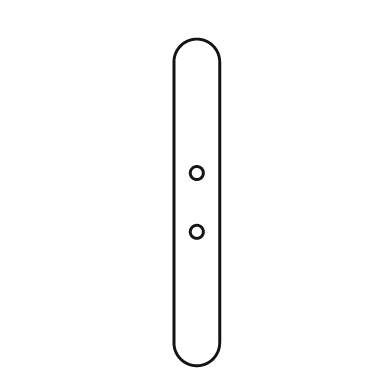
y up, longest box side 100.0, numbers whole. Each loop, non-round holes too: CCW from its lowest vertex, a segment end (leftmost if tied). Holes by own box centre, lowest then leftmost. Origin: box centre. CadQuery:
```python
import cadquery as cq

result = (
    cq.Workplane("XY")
    .moveTo(-7.0, -43.0)
    .threePointArc((0.0, -50.0), (7.0, -43.0))
    .lineTo(7.0, 43.0)
    .threePointArc((0.0, 50.0), (-7.0, 43.0))
    .close()
    .moveTo(0.0, -9.0)
    .circle(2.0)
    .moveTo(0.0, 9.0)
    .circle(2.0)
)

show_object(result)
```